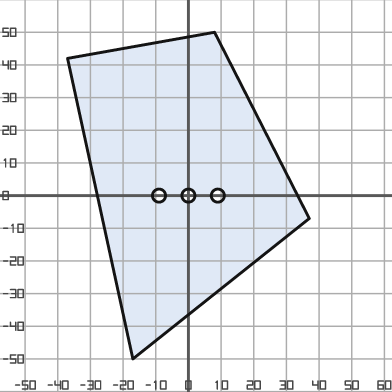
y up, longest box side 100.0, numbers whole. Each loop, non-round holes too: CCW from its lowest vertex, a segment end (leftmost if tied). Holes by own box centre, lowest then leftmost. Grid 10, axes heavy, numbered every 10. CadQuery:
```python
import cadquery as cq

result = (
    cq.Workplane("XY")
    .moveTo(-17.0, -50.0)
    .lineTo(37.0, -7.0)
    .lineTo(8.0, 50.0)
    .lineTo(-37.0, 42.0)
    .close()
    .moveTo(-9.0, 0.0)
    .circle(2.0)
    .moveTo(0.0, 0.0)
    .circle(2.0)
    .moveTo(9.0, 0.0)
    .circle(2.0)
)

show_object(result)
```